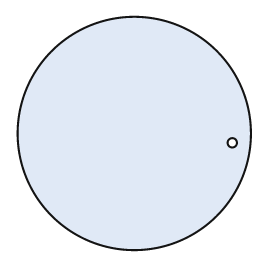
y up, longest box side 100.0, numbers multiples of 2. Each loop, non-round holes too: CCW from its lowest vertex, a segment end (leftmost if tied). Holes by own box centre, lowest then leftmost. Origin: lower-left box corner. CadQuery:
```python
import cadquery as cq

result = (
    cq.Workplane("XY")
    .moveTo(50.0, 50.0)
    .circle(50.0)
    .moveTo(92.0, 46.0)
    .circle(2.0)
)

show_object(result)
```